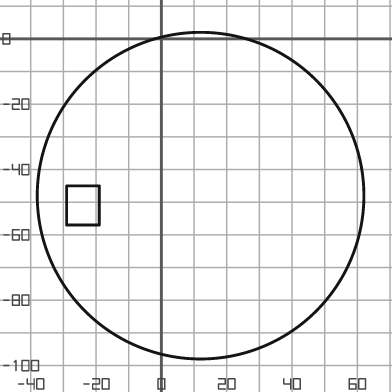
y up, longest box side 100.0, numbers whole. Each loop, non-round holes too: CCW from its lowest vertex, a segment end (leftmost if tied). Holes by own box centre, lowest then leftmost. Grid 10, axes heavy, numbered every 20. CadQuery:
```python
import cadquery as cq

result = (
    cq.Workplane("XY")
    .moveTo(12.0, -48.0)
    .circle(50.0)
    .moveTo(-29.0, -57.0)
    .lineTo(-19.0, -57.0)
    .lineTo(-19.0, -45.0)
    .lineTo(-29.0, -45.0)
    .close()
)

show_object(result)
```